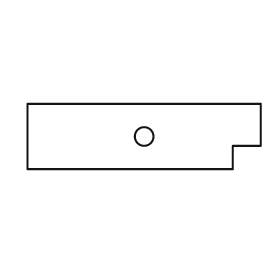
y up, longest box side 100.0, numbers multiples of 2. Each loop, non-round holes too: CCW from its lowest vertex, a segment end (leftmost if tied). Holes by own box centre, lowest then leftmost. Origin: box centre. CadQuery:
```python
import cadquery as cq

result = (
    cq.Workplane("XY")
    .moveTo(-50.0, -14.0)
    .lineTo(38.0, -14.0)
    .lineTo(38.0, -4.0)
    .lineTo(50.0, -4.0)
    .lineTo(50.0, 14.0)
    .lineTo(-50.0, 14.0)
    .close()
    .moveTo(0.0, 0.0)
    .circle(4.0)
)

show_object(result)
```